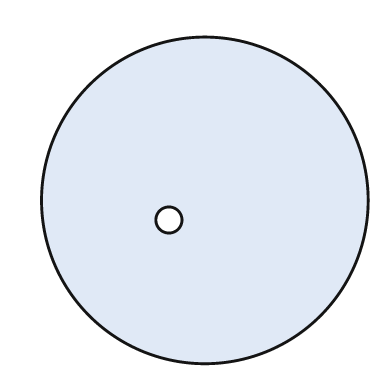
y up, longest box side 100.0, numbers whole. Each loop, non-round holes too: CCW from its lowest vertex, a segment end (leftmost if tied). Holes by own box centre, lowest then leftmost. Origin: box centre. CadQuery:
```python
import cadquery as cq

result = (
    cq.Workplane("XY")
    .moveTo(0.0, 0.0)
    .circle(50.0)
    .moveTo(-11.0, -6.0)
    .circle(4.0)
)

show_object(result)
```